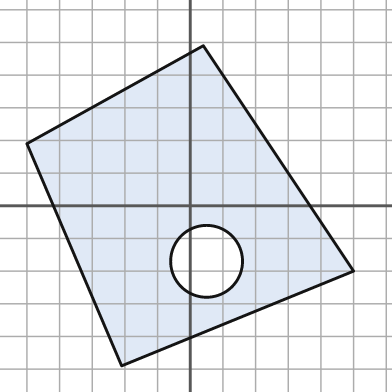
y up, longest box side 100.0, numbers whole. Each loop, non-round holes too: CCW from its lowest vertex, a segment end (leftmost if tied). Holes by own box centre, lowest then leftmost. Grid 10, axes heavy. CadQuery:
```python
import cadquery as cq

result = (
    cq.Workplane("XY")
    .moveTo(-21.0, -49.0)
    .lineTo(50.0, -20.0)
    .lineTo(4.0, 49.0)
    .lineTo(-50.0, 19.0)
    .close()
    .moveTo(5.0, -17.0)
    .circle(11.0)
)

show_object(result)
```